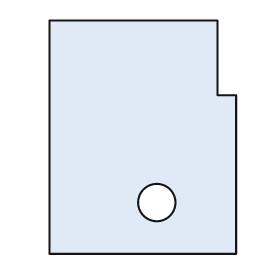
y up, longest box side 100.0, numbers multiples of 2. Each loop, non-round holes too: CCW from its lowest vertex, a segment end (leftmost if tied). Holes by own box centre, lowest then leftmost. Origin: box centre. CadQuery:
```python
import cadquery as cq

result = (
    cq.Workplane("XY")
    .moveTo(-40.0, -50.0)
    .lineTo(40.0, -50.0)
    .lineTo(40.0, 18.0)
    .lineTo(32.0, 18.0)
    .lineTo(32.0, 50.0)
    .lineTo(-40.0, 50.0)
    .close()
    .moveTo(6.0, -28.0)
    .circle(8.0)
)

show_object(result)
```